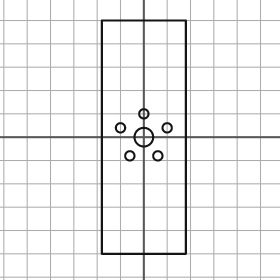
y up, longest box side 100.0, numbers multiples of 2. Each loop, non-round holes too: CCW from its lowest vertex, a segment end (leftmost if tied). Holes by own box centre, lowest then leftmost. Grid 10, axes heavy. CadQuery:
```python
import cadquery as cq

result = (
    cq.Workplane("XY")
    .moveTo(-18.0, -50.0)
    .lineTo(18.0, -50.0)
    .lineTo(18.0, 50.0)
    .lineTo(-18.0, 50.0)
    .close()
    .moveTo(-6.0, -8.0)
    .circle(2.0)
    .moveTo(6.0, -8.0)
    .circle(2.0)
    .moveTo(0.0, 0.0)
    .circle(4.0)
    .moveTo(-10.0, 4.0)
    .circle(2.0)
    .moveTo(10.0, 4.0)
    .circle(2.0)
    .moveTo(0.0, 10.0)
    .circle(2.0)
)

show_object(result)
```